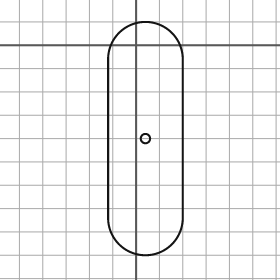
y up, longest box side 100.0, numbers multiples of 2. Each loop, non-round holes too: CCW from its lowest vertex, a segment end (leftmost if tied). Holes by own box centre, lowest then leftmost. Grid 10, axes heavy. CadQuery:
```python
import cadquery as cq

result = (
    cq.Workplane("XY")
    .moveTo(-12.0, -74.0)
    .threePointArc((4.0, -90.0), (20.0, -74.0))
    .lineTo(20.0, -6.0)
    .threePointArc((4.0, 10.0), (-12.0, -6.0))
    .close()
    .moveTo(4.0, -40.0)
    .circle(2.0)
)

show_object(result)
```